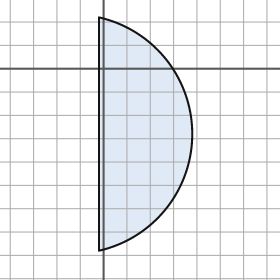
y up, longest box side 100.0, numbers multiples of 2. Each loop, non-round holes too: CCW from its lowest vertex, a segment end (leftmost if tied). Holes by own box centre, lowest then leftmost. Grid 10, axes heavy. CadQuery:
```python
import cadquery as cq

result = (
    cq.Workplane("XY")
    .moveTo(-2.0, -78.0)
    .threePointArc((38.0, -28.0), (-2.0, 22.0))
    .close()
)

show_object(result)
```